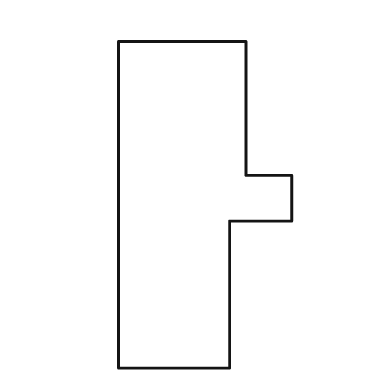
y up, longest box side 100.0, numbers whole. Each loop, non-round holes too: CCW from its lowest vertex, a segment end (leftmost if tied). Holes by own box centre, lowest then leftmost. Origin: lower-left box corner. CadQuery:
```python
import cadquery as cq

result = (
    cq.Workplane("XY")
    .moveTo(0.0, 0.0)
    .lineTo(34.0, 0.0)
    .lineTo(34.0, 45.0)
    .lineTo(53.0, 45.0)
    .lineTo(53.0, 59.0)
    .lineTo(39.0, 59.0)
    .lineTo(39.0, 100.0)
    .lineTo(0.0, 100.0)
    .close()
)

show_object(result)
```